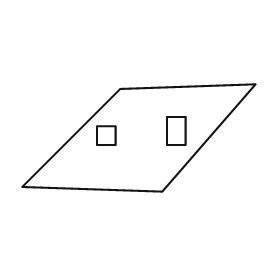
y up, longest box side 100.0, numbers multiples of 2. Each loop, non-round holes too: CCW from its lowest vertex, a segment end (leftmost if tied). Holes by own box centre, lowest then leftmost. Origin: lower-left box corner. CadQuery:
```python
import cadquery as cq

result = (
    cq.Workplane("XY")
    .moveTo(60.0, 0.0)
    .lineTo(100.0, 46.0)
    .lineTo(42.0, 44.0)
    .lineTo(0.0, 2.0)
    .close()
    .moveTo(32.0, 20.0)
    .lineTo(40.0, 20.0)
    .lineTo(40.0, 28.0)
    .lineTo(32.0, 28.0)
    .close()
    .moveTo(62.0, 20.0)
    .lineTo(70.0, 20.0)
    .lineTo(70.0, 32.0)
    .lineTo(62.0, 32.0)
    .close()
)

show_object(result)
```